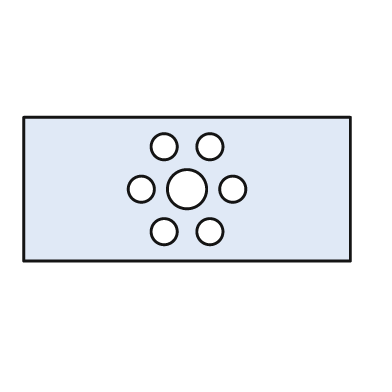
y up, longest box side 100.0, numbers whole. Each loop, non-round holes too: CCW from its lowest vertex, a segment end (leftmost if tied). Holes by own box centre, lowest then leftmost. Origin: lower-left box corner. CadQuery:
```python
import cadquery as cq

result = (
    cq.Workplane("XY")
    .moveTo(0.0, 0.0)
    .lineTo(100.0, 0.0)
    .lineTo(100.0, 44.0)
    .lineTo(0.0, 44.0)
    .close()
    .moveTo(43.0, 9.0)
    .circle(4.0)
    .moveTo(57.0, 9.0)
    .circle(4.0)
    .moveTo(36.0, 22.0)
    .circle(4.0)
    .moveTo(50.0, 22.0)
    .circle(6.0)
    .moveTo(64.0, 22.0)
    .circle(4.0)
    .moveTo(43.0, 35.0)
    .circle(4.0)
    .moveTo(57.0, 35.0)
    .circle(4.0)
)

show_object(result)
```